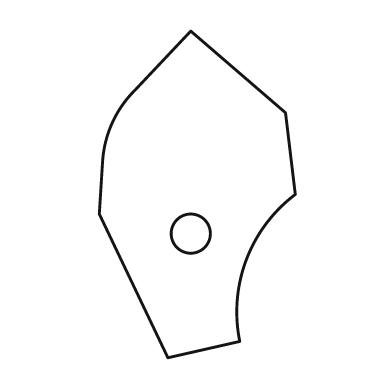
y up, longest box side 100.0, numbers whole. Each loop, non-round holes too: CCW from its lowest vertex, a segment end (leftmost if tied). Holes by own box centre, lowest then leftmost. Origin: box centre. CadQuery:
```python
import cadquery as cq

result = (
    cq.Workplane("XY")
    .moveTo(-9.0, -50.0)
    .lineTo(13.0, -45.0)
    .threePointArc((15.0, -20.0), (30.0, 0.0))
    .lineTo(27.0, 25.0)
    .lineTo(-2.0, 50.0)
    .lineTo(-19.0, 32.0)
    .threePointArc((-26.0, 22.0), (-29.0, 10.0))
    .lineTo(-30.0, -6.0)
    .close()
    .moveTo(-2.0, -12.0)
    .circle(6.0)
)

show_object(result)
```